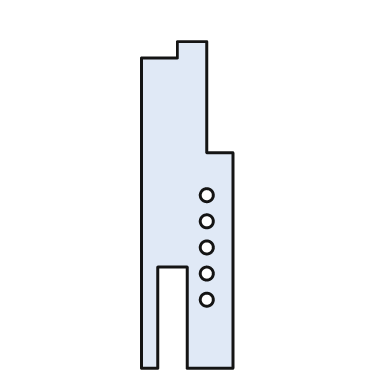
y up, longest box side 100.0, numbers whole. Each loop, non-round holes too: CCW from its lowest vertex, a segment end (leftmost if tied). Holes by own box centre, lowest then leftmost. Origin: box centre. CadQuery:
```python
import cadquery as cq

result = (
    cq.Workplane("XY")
    .moveTo(-14.0, -50.0)
    .lineTo(-9.0, -50.0)
    .lineTo(-9.0, -19.0)
    .lineTo(0.0, -19.0)
    .lineTo(0.0, -50.0)
    .lineTo(14.0, -50.0)
    .lineTo(14.0, 16.0)
    .lineTo(6.0, 16.0)
    .lineTo(6.0, 50.0)
    .lineTo(-3.0, 50.0)
    .lineTo(-3.0, 45.0)
    .lineTo(-14.0, 45.0)
    .close()
    .moveTo(6.0, -29.0)
    .circle(2.0)
    .moveTo(6.0, -21.0)
    .circle(2.0)
    .moveTo(6.0, -13.0)
    .circle(2.0)
    .moveTo(6.0, -5.0)
    .circle(2.0)
    .moveTo(6.0, 3.0)
    .circle(2.0)
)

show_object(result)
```